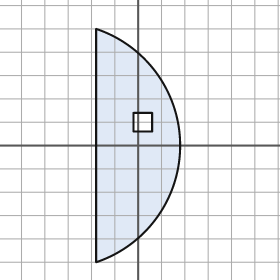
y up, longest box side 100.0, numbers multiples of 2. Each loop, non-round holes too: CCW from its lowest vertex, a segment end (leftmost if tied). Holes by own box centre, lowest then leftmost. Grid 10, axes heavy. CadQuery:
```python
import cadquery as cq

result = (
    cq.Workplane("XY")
    .moveTo(-18.0, -50.0)
    .threePointArc((18.0, 0.0), (-18.0, 50.0))
    .close()
    .moveTo(-2.0, 6.0)
    .lineTo(6.0, 6.0)
    .lineTo(6.0, 14.0)
    .lineTo(-2.0, 14.0)
    .close()
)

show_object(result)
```